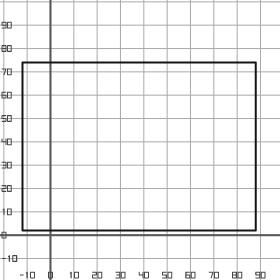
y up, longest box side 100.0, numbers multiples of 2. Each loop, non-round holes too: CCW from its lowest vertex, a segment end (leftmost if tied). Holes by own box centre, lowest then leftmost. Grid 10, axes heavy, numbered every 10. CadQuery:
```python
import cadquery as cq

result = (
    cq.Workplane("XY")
    .moveTo(-12.0, 2.0)
    .lineTo(88.0, 2.0)
    .lineTo(88.0, 74.0)
    .lineTo(-12.0, 74.0)
    .close()
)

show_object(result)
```